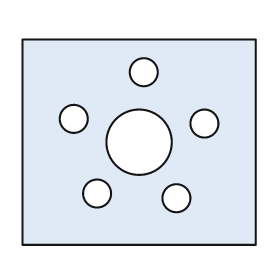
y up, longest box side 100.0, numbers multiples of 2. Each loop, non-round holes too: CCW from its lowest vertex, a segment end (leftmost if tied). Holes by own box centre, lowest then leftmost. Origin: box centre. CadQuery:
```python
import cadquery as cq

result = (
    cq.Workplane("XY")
    .moveTo(-50.0, -44.0)
    .lineTo(50.0, -44.0)
    .lineTo(50.0, 44.0)
    .lineTo(-50.0, 44.0)
    .close()
    .moveTo(16.0, -24.0)
    .circle(6.0)
    .moveTo(-18.0, -22.0)
    .circle(6.0)
    .moveTo(0.0, 0.0)
    .circle(14.0)
    .moveTo(28.0, 8.0)
    .circle(6.0)
    .moveTo(-28.0, 10.0)
    .circle(6.0)
    .moveTo(2.0, 30.0)
    .circle(6.0)
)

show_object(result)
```